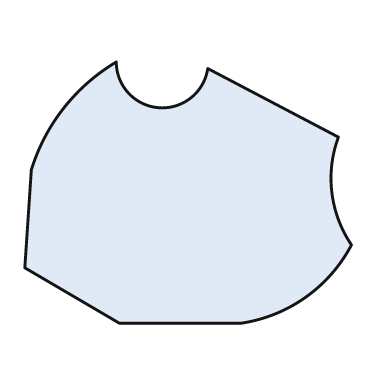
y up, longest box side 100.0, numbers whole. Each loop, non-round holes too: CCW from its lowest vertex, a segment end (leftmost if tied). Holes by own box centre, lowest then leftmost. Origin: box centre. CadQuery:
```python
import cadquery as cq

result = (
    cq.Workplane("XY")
    .moveTo(-21.0, -40.0)
    .lineTo(16.0, -40.0)
    .threePointArc((36.0, -32.0), (50.0, -16.0))
    .threePointArc((44.0, 0.0), (46.0, 17.0))
    .lineTo(6.0, 38.0)
    .threePointArc((-9.0, 26.0), (-22.0, 40.0))
    .threePointArc((-38.0, 26.0), (-48.0, 7.0))
    .lineTo(-50.0, -23.0)
    .close()
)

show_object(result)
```